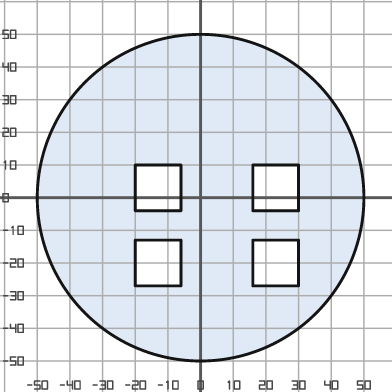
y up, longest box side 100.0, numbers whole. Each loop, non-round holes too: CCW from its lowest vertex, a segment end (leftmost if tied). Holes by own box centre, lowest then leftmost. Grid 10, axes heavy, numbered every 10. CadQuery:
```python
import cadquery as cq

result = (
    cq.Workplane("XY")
    .moveTo(0.0, 0.0)
    .circle(50.0)
    .moveTo(-20.0, -27.0)
    .lineTo(-6.0, -27.0)
    .lineTo(-6.0, -13.0)
    .lineTo(-20.0, -13.0)
    .close()
    .moveTo(16.0, -27.0)
    .lineTo(30.0, -27.0)
    .lineTo(30.0, -13.0)
    .lineTo(16.0, -13.0)
    .close()
    .moveTo(-20.0, -4.0)
    .lineTo(-6.0, -4.0)
    .lineTo(-6.0, 10.0)
    .lineTo(-20.0, 10.0)
    .close()
    .moveTo(16.0, -4.0)
    .lineTo(30.0, -4.0)
    .lineTo(30.0, 10.0)
    .lineTo(16.0, 10.0)
    .close()
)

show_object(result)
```